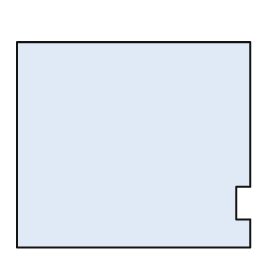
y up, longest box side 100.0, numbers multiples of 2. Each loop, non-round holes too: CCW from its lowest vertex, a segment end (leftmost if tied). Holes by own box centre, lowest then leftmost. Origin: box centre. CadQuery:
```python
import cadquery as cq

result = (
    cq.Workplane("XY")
    .moveTo(-50.0, -44.0)
    .lineTo(50.0, -44.0)
    .lineTo(50.0, -32.0)
    .lineTo(44.0, -32.0)
    .lineTo(44.0, -18.0)
    .lineTo(50.0, -18.0)
    .lineTo(50.0, 44.0)
    .lineTo(-50.0, 44.0)
    .close()
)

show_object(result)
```